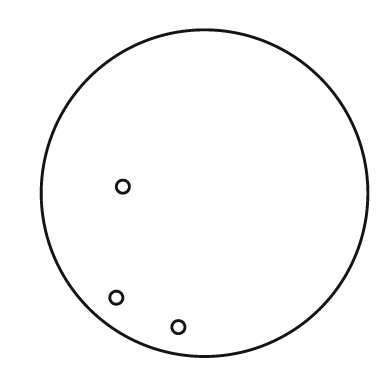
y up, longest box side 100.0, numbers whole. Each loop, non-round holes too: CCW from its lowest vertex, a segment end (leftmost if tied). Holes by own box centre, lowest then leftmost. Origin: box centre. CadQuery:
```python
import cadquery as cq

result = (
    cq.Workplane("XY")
    .moveTo(0.0, 0.0)
    .circle(50.0)
    .moveTo(-8.0, -41.0)
    .circle(2.0)
    .moveTo(-27.0, -32.0)
    .circle(2.0)
    .moveTo(-25.0, 2.0)
    .circle(2.0)
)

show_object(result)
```